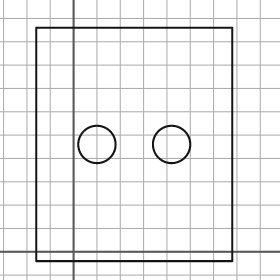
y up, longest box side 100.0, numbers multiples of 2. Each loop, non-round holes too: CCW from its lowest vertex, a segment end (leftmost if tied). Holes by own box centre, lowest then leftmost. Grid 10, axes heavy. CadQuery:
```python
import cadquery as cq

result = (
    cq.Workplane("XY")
    .moveTo(-16.0, -4.0)
    .lineTo(68.0, -4.0)
    .lineTo(68.0, 96.0)
    .lineTo(-16.0, 96.0)
    .close()
    .moveTo(10.0, 46.0)
    .circle(8.0)
    .moveTo(42.0, 46.0)
    .circle(8.0)
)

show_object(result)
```